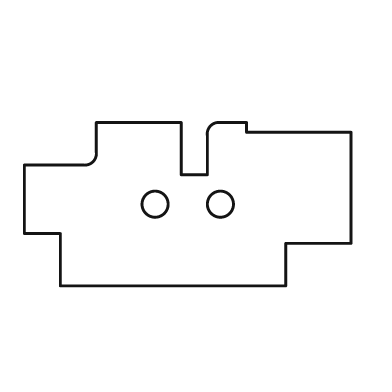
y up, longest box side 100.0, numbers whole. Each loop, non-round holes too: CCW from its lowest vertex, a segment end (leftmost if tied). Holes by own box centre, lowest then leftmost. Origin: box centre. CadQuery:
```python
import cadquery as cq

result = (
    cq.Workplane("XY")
    .moveTo(-39.0, -25.0)
    .lineTo(30.0, -25.0)
    .lineTo(30.0, -12.0)
    .lineTo(50.0, -12.0)
    .lineTo(50.0, 22.0)
    .lineTo(18.0, 22.0)
    .lineTo(18.0, 25.0)
    .lineTo(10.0, 25.0)
    .threePointArc((7.0, 24.0), (6.0, 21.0))
    .lineTo(6.0, 9.0)
    .lineTo(-2.0, 9.0)
    .lineTo(-2.0, 25.0)
    .lineTo(-28.0, 25.0)
    .lineTo(-28.0, 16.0)
    .threePointArc((-29.0, 13.0), (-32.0, 12.0))
    .lineTo(-50.0, 12.0)
    .lineTo(-50.0, -9.0)
    .lineTo(-39.0, -9.0)
    .close()
    .moveTo(-10.0, 0.0)
    .circle(4.0)
    .moveTo(10.0, 0.0)
    .circle(4.0)
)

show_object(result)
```